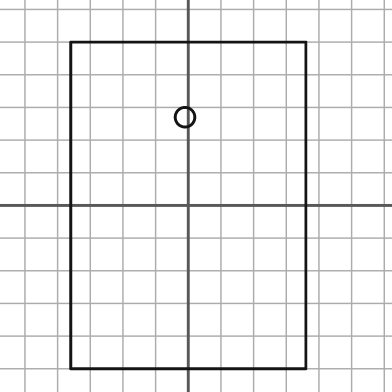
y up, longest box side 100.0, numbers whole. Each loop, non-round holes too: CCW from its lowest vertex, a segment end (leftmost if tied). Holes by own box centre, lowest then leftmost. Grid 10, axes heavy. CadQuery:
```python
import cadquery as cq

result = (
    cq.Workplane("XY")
    .moveTo(-36.0, -50.0)
    .lineTo(36.0, -50.0)
    .lineTo(36.0, 50.0)
    .lineTo(-36.0, 50.0)
    .close()
    .moveTo(-1.0, 27.0)
    .circle(3.0)
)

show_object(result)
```